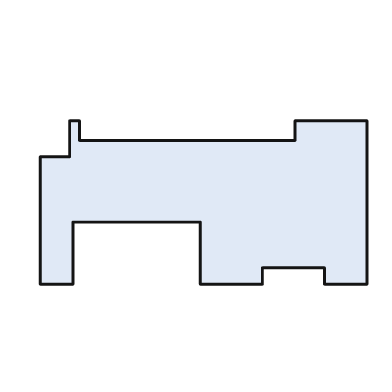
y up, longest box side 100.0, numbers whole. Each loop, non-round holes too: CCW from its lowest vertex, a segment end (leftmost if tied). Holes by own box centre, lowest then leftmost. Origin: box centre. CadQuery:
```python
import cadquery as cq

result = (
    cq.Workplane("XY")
    .moveTo(-50.0, -25.0)
    .lineTo(-40.0, -25.0)
    .lineTo(-40.0, -6.0)
    .lineTo(-1.0, -6.0)
    .lineTo(-1.0, -25.0)
    .lineTo(18.0, -25.0)
    .lineTo(18.0, -20.0)
    .lineTo(37.0, -20.0)
    .lineTo(37.0, -25.0)
    .lineTo(50.0, -25.0)
    .lineTo(50.0, 25.0)
    .lineTo(28.0, 25.0)
    .lineTo(28.0, 19.0)
    .lineTo(-38.0, 19.0)
    .lineTo(-38.0, 25.0)
    .lineTo(-41.0, 25.0)
    .lineTo(-41.0, 14.0)
    .lineTo(-50.0, 14.0)
    .close()
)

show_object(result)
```